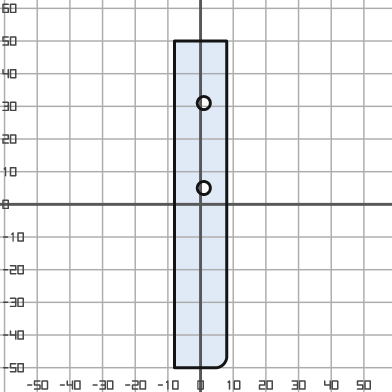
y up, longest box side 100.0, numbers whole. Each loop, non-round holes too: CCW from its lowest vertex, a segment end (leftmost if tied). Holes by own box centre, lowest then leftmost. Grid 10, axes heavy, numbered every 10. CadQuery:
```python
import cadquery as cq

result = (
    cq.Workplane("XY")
    .moveTo(-8.0, -50.0)
    .lineTo(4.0, -50.0)
    .threePointArc((7.0, -49.0), (8.0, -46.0))
    .lineTo(8.0, 50.0)
    .lineTo(-8.0, 50.0)
    .close()
    .moveTo(1.0, 5.0)
    .circle(2.0)
    .moveTo(1.0, 31.0)
    .circle(2.0)
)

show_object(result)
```